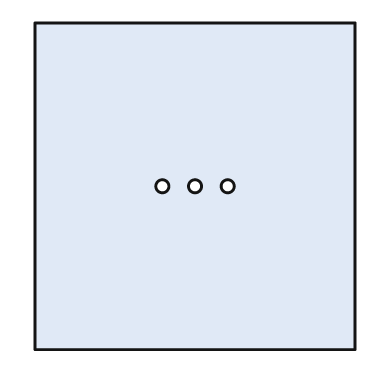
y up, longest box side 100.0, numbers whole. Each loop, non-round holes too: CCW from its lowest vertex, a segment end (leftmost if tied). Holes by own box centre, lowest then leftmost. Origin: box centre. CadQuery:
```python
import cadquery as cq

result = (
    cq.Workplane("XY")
    .moveTo(-49.0, -50.0)
    .lineTo(49.0, -50.0)
    .lineTo(49.0, 50.0)
    .lineTo(-49.0, 50.0)
    .close()
    .moveTo(-10.0, 0.0)
    .circle(2.0)
    .moveTo(0.0, 0.0)
    .circle(2.0)
    .moveTo(10.0, 0.0)
    .circle(2.0)
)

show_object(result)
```